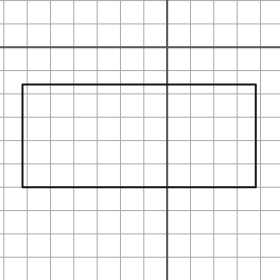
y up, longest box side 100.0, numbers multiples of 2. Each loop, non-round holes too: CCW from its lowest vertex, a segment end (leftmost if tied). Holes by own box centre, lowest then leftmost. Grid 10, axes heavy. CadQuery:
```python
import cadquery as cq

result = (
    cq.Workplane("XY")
    .moveTo(-62.0, -60.0)
    .lineTo(38.0, -60.0)
    .lineTo(38.0, -16.0)
    .lineTo(-62.0, -16.0)
    .close()
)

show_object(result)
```